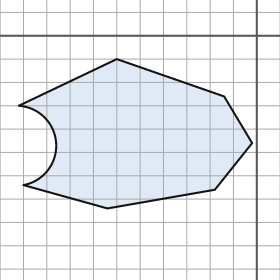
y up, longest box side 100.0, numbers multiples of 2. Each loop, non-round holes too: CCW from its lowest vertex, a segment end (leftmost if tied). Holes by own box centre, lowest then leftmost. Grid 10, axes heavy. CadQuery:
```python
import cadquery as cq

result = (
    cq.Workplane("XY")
    .moveTo(-64.0, -74.0)
    .lineTo(-18.0, -66.0)
    .lineTo(-2.0, -46.0)
    .lineTo(-14.0, -26.0)
    .lineTo(-60.0, -10.0)
    .lineTo(-102.0, -30.0)
    .threePointArc((-86.0, -46.0), (-100.0, -64.0))
    .close()
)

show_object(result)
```